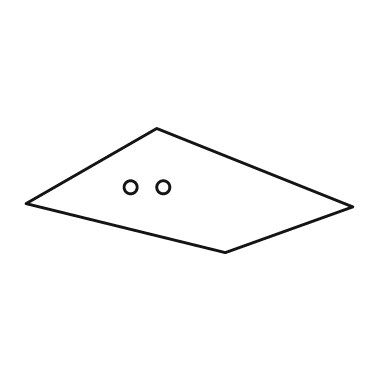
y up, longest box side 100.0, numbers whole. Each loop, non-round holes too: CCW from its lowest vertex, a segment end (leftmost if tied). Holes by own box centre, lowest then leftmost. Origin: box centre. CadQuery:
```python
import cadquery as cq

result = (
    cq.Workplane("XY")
    .moveTo(11.0, -19.0)
    .lineTo(50.0, -5.0)
    .lineTo(-10.0, 19.0)
    .lineTo(-50.0, -4.0)
    .close()
    .moveTo(-18.0, 1.0)
    .circle(2.0)
    .moveTo(-8.0, 1.0)
    .circle(2.0)
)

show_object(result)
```